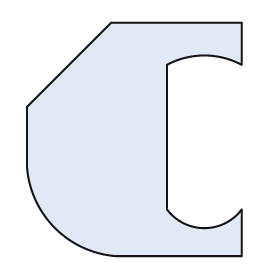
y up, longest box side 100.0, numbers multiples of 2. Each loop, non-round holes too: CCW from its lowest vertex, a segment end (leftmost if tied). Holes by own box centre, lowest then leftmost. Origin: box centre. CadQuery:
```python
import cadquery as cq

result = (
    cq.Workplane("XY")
    .moveTo(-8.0, -50.0)
    .lineTo(46.0, -50.0)
    .lineTo(46.0, -30.0)
    .threePointArc((30.0, -38.0), (14.0, -30.0))
    .lineTo(14.0, 32.0)
    .threePointArc((30.0, 36.0), (46.0, 32.0))
    .lineTo(46.0, 50.0)
    .lineTo(-10.0, 50.0)
    .lineTo(-46.0, 14.0)
    .lineTo(-46.0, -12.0)
    .threePointArc((-34.0, -38.0), (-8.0, -50.0))
    .close()
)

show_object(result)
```